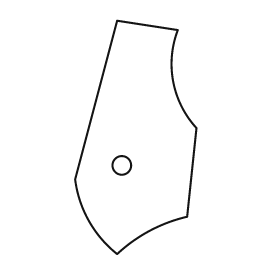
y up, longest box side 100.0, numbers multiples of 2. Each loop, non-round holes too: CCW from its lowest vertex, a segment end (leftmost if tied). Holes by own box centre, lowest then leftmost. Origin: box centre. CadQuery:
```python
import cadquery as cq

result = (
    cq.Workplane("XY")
    .moveTo(-8.0, -50.0)
    .threePointArc((6.0, -40.0), (22.0, -34.0))
    .lineTo(26.0, 4.0)
    .threePointArc((16.0, 24.0), (18.0, 46.0))
    .lineTo(-8.0, 50.0)
    .lineTo(-26.0, -18.0)
    .threePointArc((-20.0, -36.0), (-8.0, -50.0))
    .close()
    .moveTo(-6.0, -12.0)
    .circle(4.0)
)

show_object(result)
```